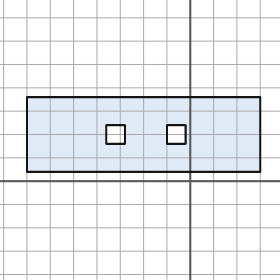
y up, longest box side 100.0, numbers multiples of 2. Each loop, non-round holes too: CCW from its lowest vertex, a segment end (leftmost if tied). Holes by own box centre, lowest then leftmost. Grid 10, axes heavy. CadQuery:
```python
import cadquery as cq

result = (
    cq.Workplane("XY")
    .moveTo(-70.0, 4.0)
    .lineTo(30.0, 4.0)
    .lineTo(30.0, 36.0)
    .lineTo(-70.0, 36.0)
    .close()
    .moveTo(-36.0, 16.0)
    .lineTo(-28.0, 16.0)
    .lineTo(-28.0, 24.0)
    .lineTo(-36.0, 24.0)
    .close()
    .moveTo(-10.0, 16.0)
    .lineTo(-2.0, 16.0)
    .lineTo(-2.0, 24.0)
    .lineTo(-10.0, 24.0)
    .close()
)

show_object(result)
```